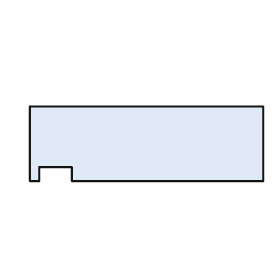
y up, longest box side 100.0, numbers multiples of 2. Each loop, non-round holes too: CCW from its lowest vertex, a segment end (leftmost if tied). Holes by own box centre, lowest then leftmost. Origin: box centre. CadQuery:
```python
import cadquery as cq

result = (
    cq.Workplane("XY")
    .moveTo(-50.0, -16.0)
    .lineTo(-46.0, -16.0)
    .lineTo(-46.0, -10.0)
    .lineTo(-32.0, -10.0)
    .lineTo(-32.0, -16.0)
    .lineTo(50.0, -16.0)
    .lineTo(50.0, 16.0)
    .lineTo(-50.0, 16.0)
    .close()
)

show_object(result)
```